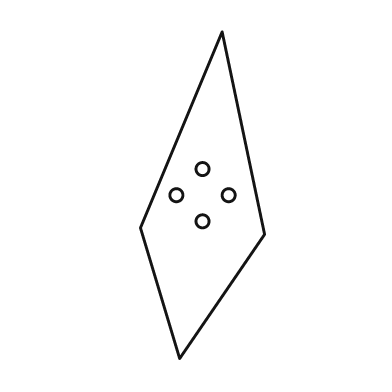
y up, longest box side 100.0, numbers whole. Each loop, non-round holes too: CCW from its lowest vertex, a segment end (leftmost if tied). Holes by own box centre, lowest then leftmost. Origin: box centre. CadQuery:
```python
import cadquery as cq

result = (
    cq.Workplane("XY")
    .moveTo(-7.0, -50.0)
    .lineTo(19.0, -12.0)
    .lineTo(6.0, 50.0)
    .lineTo(-19.0, -10.0)
    .close()
    .moveTo(0.0, -8.0)
    .circle(2.0)
    .moveTo(-8.0, 0.0)
    .circle(2.0)
    .moveTo(8.0, 0.0)
    .circle(2.0)
    .moveTo(0.0, 8.0)
    .circle(2.0)
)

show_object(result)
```